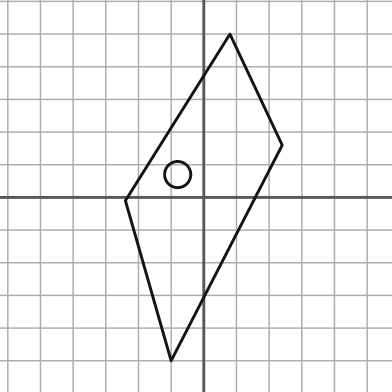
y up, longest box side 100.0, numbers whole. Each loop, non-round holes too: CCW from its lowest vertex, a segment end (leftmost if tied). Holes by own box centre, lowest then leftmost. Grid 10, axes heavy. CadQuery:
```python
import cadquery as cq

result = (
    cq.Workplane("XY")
    .moveTo(-10.0, -50.0)
    .lineTo(24.0, 16.0)
    .lineTo(8.0, 50.0)
    .lineTo(-24.0, -1.0)
    .close()
    .moveTo(-8.0, 7.0)
    .circle(4.0)
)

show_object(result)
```